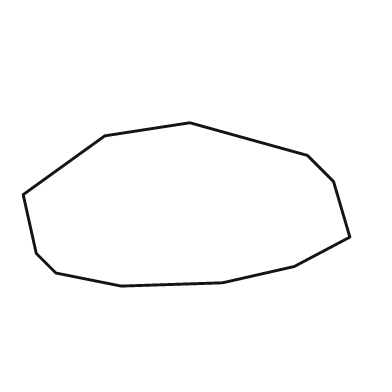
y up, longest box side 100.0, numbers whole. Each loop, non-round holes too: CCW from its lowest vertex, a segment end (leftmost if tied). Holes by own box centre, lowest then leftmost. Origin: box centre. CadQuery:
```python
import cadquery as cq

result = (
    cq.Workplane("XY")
    .moveTo(-20.0, -25.0)
    .lineTo(11.0, -24.0)
    .lineTo(33.0, -19.0)
    .lineTo(50.0, -10.0)
    .lineTo(45.0, 7.0)
    .lineTo(37.0, 15.0)
    .lineTo(1.0, 25.0)
    .lineTo(-25.0, 21.0)
    .lineTo(-50.0, 3.0)
    .lineTo(-46.0, -15.0)
    .lineTo(-40.0, -21.0)
    .close()
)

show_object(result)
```